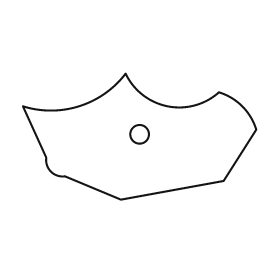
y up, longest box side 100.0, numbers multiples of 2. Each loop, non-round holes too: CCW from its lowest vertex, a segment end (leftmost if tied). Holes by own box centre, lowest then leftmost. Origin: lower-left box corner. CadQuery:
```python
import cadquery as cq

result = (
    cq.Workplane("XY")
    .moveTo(42.0, 0.0)
    .lineTo(86.0, 8.0)
    .lineTo(100.0, 30.0)
    .threePointArc((94.0, 40.0), (84.0, 46.0))
    .threePointArc((62.0, 40.0), (44.0, 54.0))
    .threePointArc((24.0, 40.0), (0.0, 40.0))
    .lineTo(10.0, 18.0)
    .threePointArc((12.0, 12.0), (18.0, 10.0))
    .close()
    .moveTo(50.0, 28.0)
    .circle(4.0)
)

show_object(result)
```